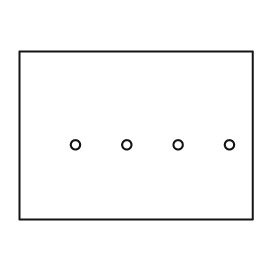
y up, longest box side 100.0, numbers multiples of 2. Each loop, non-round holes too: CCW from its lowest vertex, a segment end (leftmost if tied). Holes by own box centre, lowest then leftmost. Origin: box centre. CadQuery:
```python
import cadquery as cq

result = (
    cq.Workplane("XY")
    .moveTo(-50.0, -36.0)
    .lineTo(50.0, -36.0)
    .lineTo(50.0, 36.0)
    .lineTo(-50.0, 36.0)
    .close()
    .moveTo(-26.0, -4.0)
    .circle(2.0)
    .moveTo(-4.0, -4.0)
    .circle(2.0)
    .moveTo(18.0, -4.0)
    .circle(2.0)
    .moveTo(40.0, -4.0)
    .circle(2.0)
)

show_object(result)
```